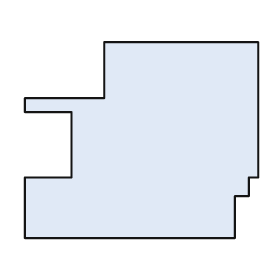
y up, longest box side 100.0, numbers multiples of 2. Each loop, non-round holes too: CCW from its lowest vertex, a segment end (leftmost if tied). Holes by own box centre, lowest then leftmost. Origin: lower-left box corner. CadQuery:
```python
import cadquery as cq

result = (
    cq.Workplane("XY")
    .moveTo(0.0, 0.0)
    .lineTo(90.0, 0.0)
    .lineTo(90.0, 18.0)
    .lineTo(96.0, 18.0)
    .lineTo(96.0, 26.0)
    .lineTo(100.0, 26.0)
    .lineTo(100.0, 84.0)
    .lineTo(34.0, 84.0)
    .lineTo(34.0, 60.0)
    .lineTo(0.0, 60.0)
    .lineTo(0.0, 54.0)
    .lineTo(20.0, 54.0)
    .lineTo(20.0, 26.0)
    .lineTo(0.0, 26.0)
    .close()
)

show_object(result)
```